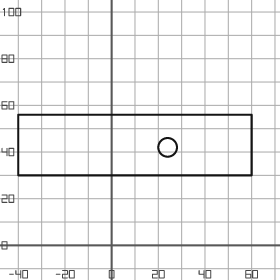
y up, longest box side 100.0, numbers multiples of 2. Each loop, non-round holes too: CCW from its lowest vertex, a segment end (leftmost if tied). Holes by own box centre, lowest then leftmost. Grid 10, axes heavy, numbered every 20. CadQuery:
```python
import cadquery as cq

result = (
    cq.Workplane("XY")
    .moveTo(-40.0, 30.0)
    .lineTo(60.0, 30.0)
    .lineTo(60.0, 56.0)
    .lineTo(-40.0, 56.0)
    .close()
    .moveTo(24.0, 42.0)
    .circle(4.0)
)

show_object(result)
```